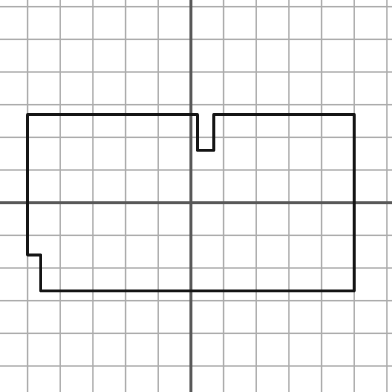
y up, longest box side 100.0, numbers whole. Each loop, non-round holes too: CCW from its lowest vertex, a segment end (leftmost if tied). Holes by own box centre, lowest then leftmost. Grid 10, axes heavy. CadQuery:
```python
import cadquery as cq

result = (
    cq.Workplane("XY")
    .moveTo(-46.0, -27.0)
    .lineTo(50.0, -27.0)
    .lineTo(50.0, 27.0)
    .lineTo(7.0, 27.0)
    .lineTo(7.0, 16.0)
    .lineTo(2.0, 16.0)
    .lineTo(2.0, 27.0)
    .lineTo(-50.0, 27.0)
    .lineTo(-50.0, -16.0)
    .lineTo(-46.0, -16.0)
    .close()
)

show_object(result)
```